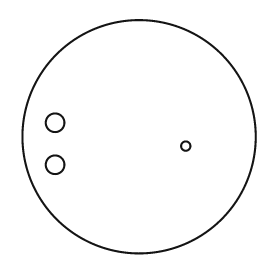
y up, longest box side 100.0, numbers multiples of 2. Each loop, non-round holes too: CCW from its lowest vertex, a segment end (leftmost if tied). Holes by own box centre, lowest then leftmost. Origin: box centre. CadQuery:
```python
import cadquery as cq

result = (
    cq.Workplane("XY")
    .moveTo(0.0, 0.0)
    .circle(50.0)
    .moveTo(-36.0, -12.0)
    .circle(4.0)
    .moveTo(20.0, -4.0)
    .circle(2.0)
    .moveTo(-36.0, 6.0)
    .circle(4.0)
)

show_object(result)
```